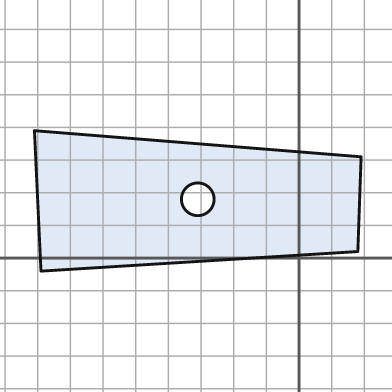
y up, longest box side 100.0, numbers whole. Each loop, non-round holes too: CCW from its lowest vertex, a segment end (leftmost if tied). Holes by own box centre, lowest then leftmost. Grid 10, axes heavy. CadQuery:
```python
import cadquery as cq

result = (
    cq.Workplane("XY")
    .moveTo(-79.0, -4.0)
    .lineTo(18.0, 2.0)
    .lineTo(19.0, 31.0)
    .lineTo(-81.0, 39.0)
    .close()
    .moveTo(-31.0, 18.0)
    .circle(5.0)
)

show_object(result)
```